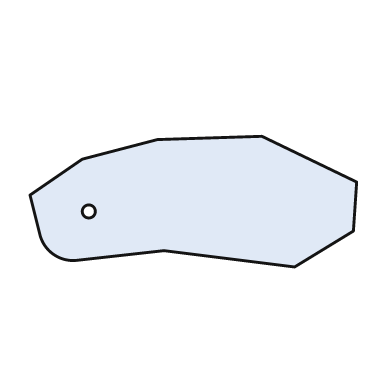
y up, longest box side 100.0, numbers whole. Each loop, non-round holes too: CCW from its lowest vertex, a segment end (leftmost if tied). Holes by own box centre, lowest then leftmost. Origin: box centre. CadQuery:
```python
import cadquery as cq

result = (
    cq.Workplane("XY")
    .moveTo(31.0, -20.0)
    .lineTo(49.0, -9.0)
    .lineTo(50.0, 6.0)
    .lineTo(21.0, 20.0)
    .lineTo(-11.0, 19.0)
    .lineTo(-34.0, 13.0)
    .lineTo(-50.0, 2.0)
    .lineTo(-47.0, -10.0)
    .threePointArc((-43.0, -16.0), (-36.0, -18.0))
    .lineTo(-9.0, -15.0)
    .close()
    .moveTo(-32.0, -3.0)
    .circle(2.0)
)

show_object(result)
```